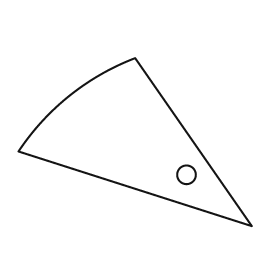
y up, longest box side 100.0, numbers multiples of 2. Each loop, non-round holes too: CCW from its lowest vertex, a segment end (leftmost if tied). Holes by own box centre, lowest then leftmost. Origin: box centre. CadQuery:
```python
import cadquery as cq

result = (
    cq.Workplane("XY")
    .moveTo(50.0, -36.0)
    .lineTo(0.0, 36.0)
    .threePointArc((-28.0, 20.0), (-50.0, -4.0))
    .close()
    .moveTo(22.0, -14.0)
    .circle(4.0)
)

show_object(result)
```